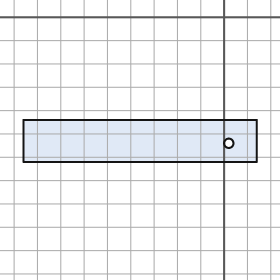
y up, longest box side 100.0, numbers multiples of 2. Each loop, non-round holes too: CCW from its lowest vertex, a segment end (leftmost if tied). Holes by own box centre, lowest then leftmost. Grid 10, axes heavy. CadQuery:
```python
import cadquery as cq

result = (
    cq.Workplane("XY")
    .moveTo(-86.0, -62.0)
    .lineTo(14.0, -62.0)
    .lineTo(14.0, -44.0)
    .lineTo(-86.0, -44.0)
    .close()
    .moveTo(2.0, -54.0)
    .circle(2.0)
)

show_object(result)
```